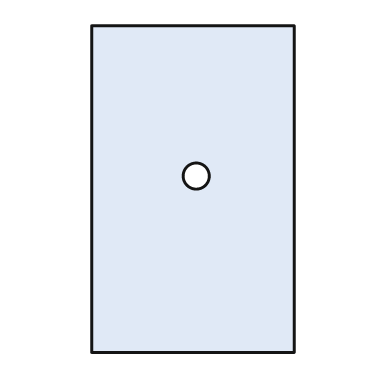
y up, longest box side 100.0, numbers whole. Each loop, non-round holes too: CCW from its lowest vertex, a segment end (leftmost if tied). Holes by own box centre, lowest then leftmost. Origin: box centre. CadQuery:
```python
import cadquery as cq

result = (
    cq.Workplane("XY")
    .moveTo(-31.0, -50.0)
    .lineTo(31.0, -50.0)
    .lineTo(31.0, 50.0)
    .lineTo(-31.0, 50.0)
    .close()
    .moveTo(1.0, 4.0)
    .circle(4.0)
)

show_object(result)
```